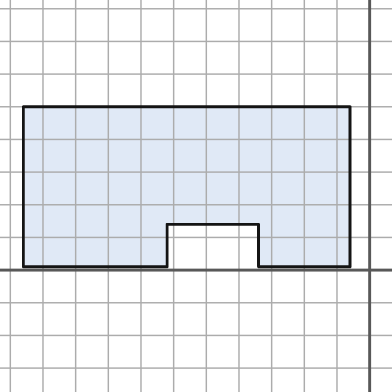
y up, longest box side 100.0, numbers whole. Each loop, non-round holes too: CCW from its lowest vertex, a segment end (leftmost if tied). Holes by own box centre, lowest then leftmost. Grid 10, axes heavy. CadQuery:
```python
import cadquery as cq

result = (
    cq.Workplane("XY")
    .moveTo(-106.0, 1.0)
    .lineTo(-62.0, 1.0)
    .lineTo(-62.0, 14.0)
    .lineTo(-34.0, 14.0)
    .lineTo(-34.0, 1.0)
    .lineTo(-6.0, 1.0)
    .lineTo(-6.0, 50.0)
    .lineTo(-106.0, 50.0)
    .close()
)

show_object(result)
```